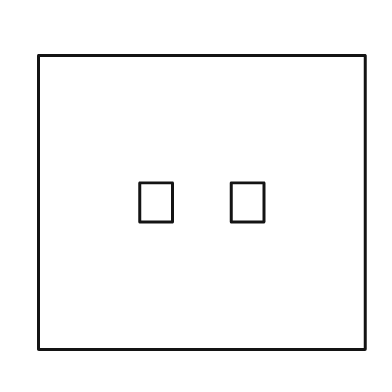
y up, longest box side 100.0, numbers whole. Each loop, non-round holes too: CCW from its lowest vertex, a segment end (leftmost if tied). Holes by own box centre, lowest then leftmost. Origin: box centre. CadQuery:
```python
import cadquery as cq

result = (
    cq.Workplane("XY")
    .moveTo(-50.0, -45.0)
    .lineTo(50.0, -45.0)
    .lineTo(50.0, 45.0)
    .lineTo(-50.0, 45.0)
    .close()
    .moveTo(-19.0, -6.0)
    .lineTo(-9.0, -6.0)
    .lineTo(-9.0, 6.0)
    .lineTo(-19.0, 6.0)
    .close()
    .moveTo(9.0, -6.0)
    .lineTo(19.0, -6.0)
    .lineTo(19.0, 6.0)
    .lineTo(9.0, 6.0)
    .close()
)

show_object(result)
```